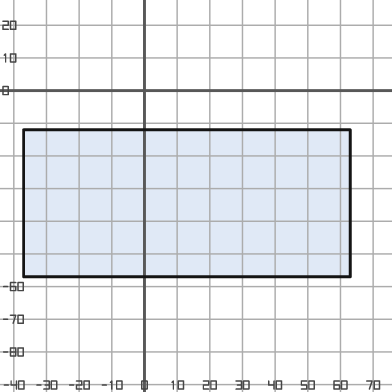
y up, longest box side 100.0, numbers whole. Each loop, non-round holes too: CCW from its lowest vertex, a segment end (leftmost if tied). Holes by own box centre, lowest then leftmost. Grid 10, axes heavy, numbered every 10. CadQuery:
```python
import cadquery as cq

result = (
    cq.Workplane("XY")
    .moveTo(-37.0, -57.0)
    .lineTo(63.0, -57.0)
    .lineTo(63.0, -12.0)
    .lineTo(-37.0, -12.0)
    .close()
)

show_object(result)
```